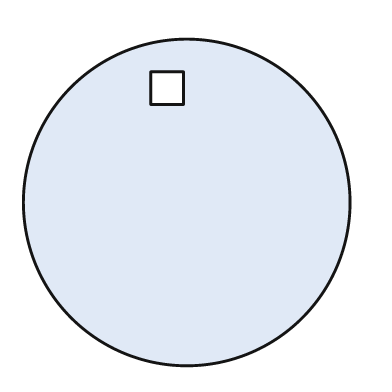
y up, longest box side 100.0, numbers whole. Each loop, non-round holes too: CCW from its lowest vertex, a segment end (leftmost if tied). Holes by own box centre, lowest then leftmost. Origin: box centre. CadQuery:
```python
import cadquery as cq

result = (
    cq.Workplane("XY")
    .moveTo(0.0, 0.0)
    .circle(50.0)
    .moveTo(-11.0, 30.0)
    .lineTo(-1.0, 30.0)
    .lineTo(-1.0, 40.0)
    .lineTo(-11.0, 40.0)
    .close()
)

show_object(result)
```